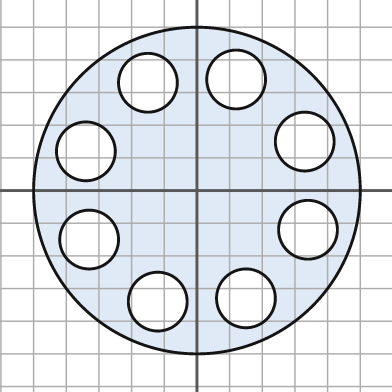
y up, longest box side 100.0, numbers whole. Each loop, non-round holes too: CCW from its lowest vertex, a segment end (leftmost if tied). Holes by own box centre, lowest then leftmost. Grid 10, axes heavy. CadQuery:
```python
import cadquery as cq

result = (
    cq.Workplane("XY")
    .moveTo(0.0, 0.0)
    .circle(50.0)
    .moveTo(-12.0, -34.0)
    .circle(9.0)
    .moveTo(15.0, -33.0)
    .circle(9.0)
    .moveTo(-33.0, -15.0)
    .circle(9.0)
    .moveTo(34.0, -12.0)
    .circle(9.0)
    .moveTo(-34.0, 12.0)
    .circle(9.0)
    .moveTo(33.0, 15.0)
    .circle(9.0)
    .moveTo(-15.0, 33.0)
    .circle(9.0)
    .moveTo(12.0, 34.0)
    .circle(9.0)
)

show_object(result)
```